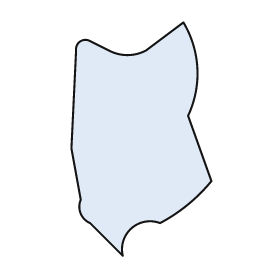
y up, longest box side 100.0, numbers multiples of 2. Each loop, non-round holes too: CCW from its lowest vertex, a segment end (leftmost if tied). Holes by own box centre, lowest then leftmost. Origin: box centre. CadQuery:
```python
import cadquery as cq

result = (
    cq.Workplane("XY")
    .moveTo(-8.0, -50.0)
    .threePointArc((-4.0, -38.0), (8.0, -36.0))
    .threePointArc((20.0, -28.0), (30.0, -18.0))
    .lineTo(20.0, 10.0)
    .threePointArc((24.0, 30.0), (18.0, 50.0))
    .lineTo(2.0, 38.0)
    .threePointArc((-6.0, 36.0), (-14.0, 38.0))
    .lineTo(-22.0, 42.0)
    .threePointArc((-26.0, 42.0), (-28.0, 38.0))
    .lineTo(-30.0, -4.0)
    .lineTo(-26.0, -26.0)
    .threePointArc((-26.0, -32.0), (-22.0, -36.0))
    .close()
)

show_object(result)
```